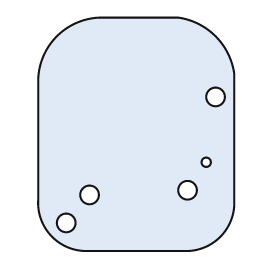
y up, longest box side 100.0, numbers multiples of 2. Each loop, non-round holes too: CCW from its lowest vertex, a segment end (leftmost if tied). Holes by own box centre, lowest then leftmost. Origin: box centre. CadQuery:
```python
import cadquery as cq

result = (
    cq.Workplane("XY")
    .moveTo(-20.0, -50.0)
    .lineTo(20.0, -50.0)
    .threePointArc((36.0, -44.0), (42.0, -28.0))
    .lineTo(42.0, 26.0)
    .threePointArc((34.0, 42.0), (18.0, 50.0))
    .lineTo(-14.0, 50.0)
    .threePointArc((-34.0, 42.0), (-42.0, 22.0))
    .lineTo(-42.0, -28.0)
    .threePointArc((-36.0, -44.0), (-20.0, -50.0))
    .close()
    .moveTo(-30.0, -38.0)
    .circle(4.0)
    .moveTo(-20.0, -26.0)
    .circle(4.0)
    .moveTo(22.0, -24.0)
    .circle(4.0)
    .moveTo(30.0, -12.0)
    .circle(2.0)
    .moveTo(34.0, 16.0)
    .circle(4.0)
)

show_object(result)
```